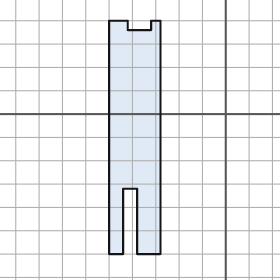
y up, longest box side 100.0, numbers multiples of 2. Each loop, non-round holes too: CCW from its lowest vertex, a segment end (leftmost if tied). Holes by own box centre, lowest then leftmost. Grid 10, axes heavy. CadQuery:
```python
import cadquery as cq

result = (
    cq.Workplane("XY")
    .moveTo(-50.0, -60.0)
    .lineTo(-44.0, -60.0)
    .lineTo(-44.0, -32.0)
    .lineTo(-38.0, -32.0)
    .lineTo(-38.0, -60.0)
    .lineTo(-28.0, -60.0)
    .lineTo(-28.0, 40.0)
    .lineTo(-32.0, 40.0)
    .lineTo(-32.0, 36.0)
    .lineTo(-42.0, 36.0)
    .lineTo(-42.0, 40.0)
    .lineTo(-50.0, 40.0)
    .close()
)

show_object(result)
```